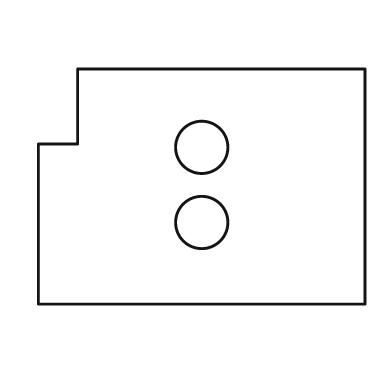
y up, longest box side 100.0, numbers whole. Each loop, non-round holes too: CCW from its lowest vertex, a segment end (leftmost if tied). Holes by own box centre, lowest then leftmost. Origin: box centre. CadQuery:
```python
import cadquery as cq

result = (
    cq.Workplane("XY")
    .moveTo(-50.0, -36.0)
    .lineTo(50.0, -36.0)
    .lineTo(50.0, 36.0)
    .lineTo(-38.0, 36.0)
    .lineTo(-38.0, 13.0)
    .lineTo(-50.0, 13.0)
    .close()
    .moveTo(0.0, -11.0)
    .circle(8.0)
    .moveTo(0.0, 12.0)
    .circle(8.0)
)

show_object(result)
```